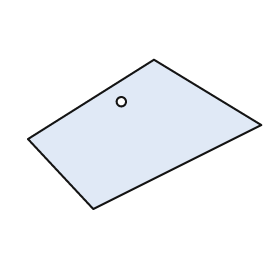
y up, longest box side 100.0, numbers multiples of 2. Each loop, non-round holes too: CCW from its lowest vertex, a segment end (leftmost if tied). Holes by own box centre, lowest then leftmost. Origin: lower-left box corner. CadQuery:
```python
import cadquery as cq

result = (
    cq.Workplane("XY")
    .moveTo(28.0, 0.0)
    .lineTo(100.0, 36.0)
    .lineTo(54.0, 64.0)
    .lineTo(0.0, 30.0)
    .close()
    .moveTo(40.0, 46.0)
    .circle(2.0)
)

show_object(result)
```